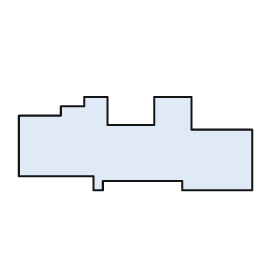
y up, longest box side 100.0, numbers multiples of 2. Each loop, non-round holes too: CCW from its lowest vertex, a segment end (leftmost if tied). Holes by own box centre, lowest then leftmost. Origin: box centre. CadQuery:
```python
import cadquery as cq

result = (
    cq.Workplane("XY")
    .moveTo(-18.0, -20.0)
    .lineTo(-14.0, -20.0)
    .lineTo(-14.0, -16.0)
    .lineTo(20.0, -16.0)
    .lineTo(20.0, -20.0)
    .lineTo(50.0, -20.0)
    .lineTo(50.0, 6.0)
    .lineTo(24.0, 6.0)
    .lineTo(24.0, 20.0)
    .lineTo(8.0, 20.0)
    .lineTo(8.0, 8.0)
    .lineTo(-12.0, 8.0)
    .lineTo(-12.0, 20.0)
    .lineTo(-22.0, 20.0)
    .lineTo(-22.0, 16.0)
    .lineTo(-32.0, 16.0)
    .lineTo(-32.0, 12.0)
    .lineTo(-50.0, 12.0)
    .lineTo(-50.0, -14.0)
    .lineTo(-18.0, -14.0)
    .close()
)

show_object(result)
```